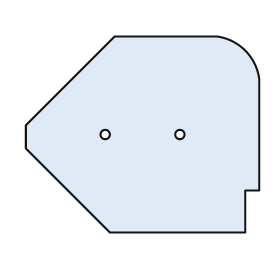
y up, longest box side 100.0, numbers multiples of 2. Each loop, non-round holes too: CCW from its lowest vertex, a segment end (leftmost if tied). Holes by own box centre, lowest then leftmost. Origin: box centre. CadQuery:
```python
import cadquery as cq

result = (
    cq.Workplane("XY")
    .moveTo(-14.0, -42.0)
    .lineTo(44.0, -42.0)
    .lineTo(44.0, -24.0)
    .lineTo(50.0, -24.0)
    .lineTo(50.0, 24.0)
    .threePointArc((44.0, 36.0), (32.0, 42.0))
    .lineTo(-12.0, 42.0)
    .lineTo(-50.0, 4.0)
    .lineTo(-50.0, -6.0)
    .close()
    .moveTo(-16.0, 0.0)
    .circle(2.0)
    .moveTo(16.0, 0.0)
    .circle(2.0)
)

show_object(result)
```